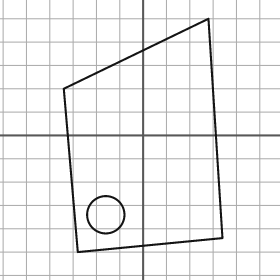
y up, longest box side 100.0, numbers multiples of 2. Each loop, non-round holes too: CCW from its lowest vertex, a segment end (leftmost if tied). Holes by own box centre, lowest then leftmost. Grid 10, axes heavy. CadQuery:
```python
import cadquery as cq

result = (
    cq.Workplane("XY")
    .moveTo(-28.0, -50.0)
    .lineTo(34.0, -44.0)
    .lineTo(28.0, 50.0)
    .lineTo(-34.0, 20.0)
    .close()
    .moveTo(-16.0, -34.0)
    .circle(8.0)
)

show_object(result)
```